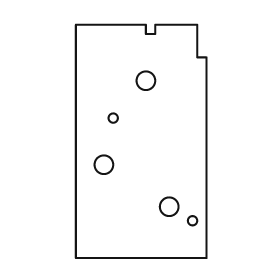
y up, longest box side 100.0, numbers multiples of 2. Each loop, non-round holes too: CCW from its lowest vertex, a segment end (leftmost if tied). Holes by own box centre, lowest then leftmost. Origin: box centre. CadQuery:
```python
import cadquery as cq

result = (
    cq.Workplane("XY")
    .moveTo(-28.0, -50.0)
    .lineTo(28.0, -50.0)
    .lineTo(28.0, 36.0)
    .lineTo(24.0, 36.0)
    .lineTo(24.0, 50.0)
    .lineTo(6.0, 50.0)
    .lineTo(6.0, 46.0)
    .lineTo(2.0, 46.0)
    .lineTo(2.0, 50.0)
    .lineTo(-28.0, 50.0)
    .close()
    .moveTo(22.0, -34.0)
    .circle(2.0)
    .moveTo(12.0, -28.0)
    .circle(4.0)
    .moveTo(-16.0, -10.0)
    .circle(4.0)
    .moveTo(-12.0, 10.0)
    .circle(2.0)
    .moveTo(2.0, 26.0)
    .circle(4.0)
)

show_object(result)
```